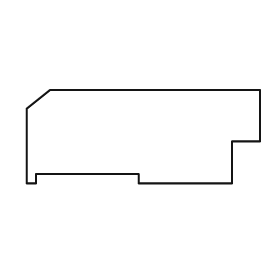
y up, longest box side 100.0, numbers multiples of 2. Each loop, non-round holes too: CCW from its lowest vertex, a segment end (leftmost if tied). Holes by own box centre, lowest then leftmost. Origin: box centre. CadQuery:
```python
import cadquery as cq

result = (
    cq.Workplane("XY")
    .moveTo(-50.0, -20.0)
    .lineTo(-46.0, -20.0)
    .lineTo(-46.0, -16.0)
    .lineTo(-2.0, -16.0)
    .lineTo(-2.0, -20.0)
    .lineTo(38.0, -20.0)
    .lineTo(38.0, -2.0)
    .lineTo(50.0, -2.0)
    .lineTo(50.0, 20.0)
    .lineTo(-40.0, 20.0)
    .lineTo(-50.0, 12.0)
    .close()
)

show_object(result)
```